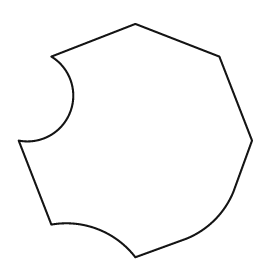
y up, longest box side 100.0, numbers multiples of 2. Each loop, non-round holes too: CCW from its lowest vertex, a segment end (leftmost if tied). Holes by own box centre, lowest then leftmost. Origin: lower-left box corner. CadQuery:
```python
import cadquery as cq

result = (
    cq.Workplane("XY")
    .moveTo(50.0, 0.0)
    .lineTo(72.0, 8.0)
    .threePointArc((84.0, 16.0), (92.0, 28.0))
    .lineTo(100.0, 50.0)
    .lineTo(86.0, 86.0)
    .lineTo(50.0, 100.0)
    .lineTo(14.0, 86.0)
    .threePointArc((22.0, 62.0), (0.0, 50.0))
    .lineTo(14.0, 14.0)
    .threePointArc((34.0, 12.0), (50.0, 0.0))
    .close()
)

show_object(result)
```